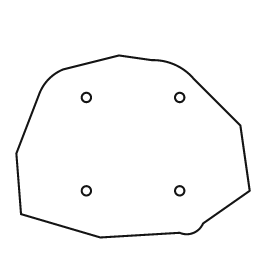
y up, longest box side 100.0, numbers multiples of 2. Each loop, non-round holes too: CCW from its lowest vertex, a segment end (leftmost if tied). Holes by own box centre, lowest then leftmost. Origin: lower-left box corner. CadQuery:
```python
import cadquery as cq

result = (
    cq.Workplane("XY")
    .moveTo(36.0, 0.0)
    .lineTo(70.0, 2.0)
    .threePointArc((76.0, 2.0), (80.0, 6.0))
    .lineTo(100.0, 20.0)
    .lineTo(96.0, 48.0)
    .lineTo(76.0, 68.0)
    .threePointArc((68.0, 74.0), (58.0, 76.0))
    .lineTo(44.0, 78.0)
    .lineTo(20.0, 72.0)
    .threePointArc((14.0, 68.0), (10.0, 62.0))
    .lineTo(0.0, 36.0)
    .lineTo(2.0, 10.0)
    .close()
    .moveTo(30.0, 20.0)
    .circle(2.0)
    .moveTo(70.0, 20.0)
    .circle(2.0)
    .moveTo(30.0, 60.0)
    .circle(2.0)
    .moveTo(70.0, 60.0)
    .circle(2.0)
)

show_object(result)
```